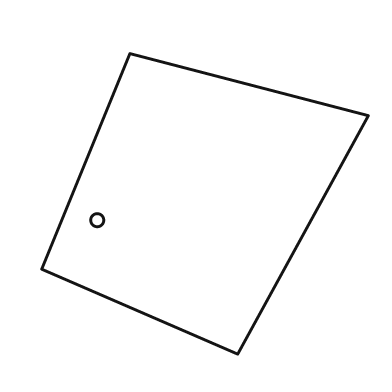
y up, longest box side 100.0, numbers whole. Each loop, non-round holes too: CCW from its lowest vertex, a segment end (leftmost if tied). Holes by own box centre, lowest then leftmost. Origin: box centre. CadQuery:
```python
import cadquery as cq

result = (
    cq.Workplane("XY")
    .moveTo(10.0, -46.0)
    .lineTo(50.0, 27.0)
    .lineTo(-23.0, 46.0)
    .lineTo(-50.0, -20.0)
    .close()
    .moveTo(-33.0, -5.0)
    .circle(2.0)
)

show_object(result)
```